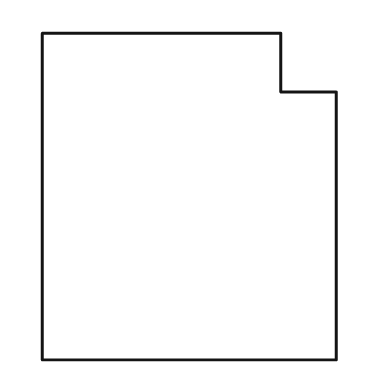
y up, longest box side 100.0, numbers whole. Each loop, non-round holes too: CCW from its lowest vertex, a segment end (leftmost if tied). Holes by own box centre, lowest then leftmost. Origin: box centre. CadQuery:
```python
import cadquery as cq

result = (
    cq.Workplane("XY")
    .moveTo(-45.0, -50.0)
    .lineTo(45.0, -50.0)
    .lineTo(45.0, 32.0)
    .lineTo(28.0, 32.0)
    .lineTo(28.0, 50.0)
    .lineTo(-45.0, 50.0)
    .close()
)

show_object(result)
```